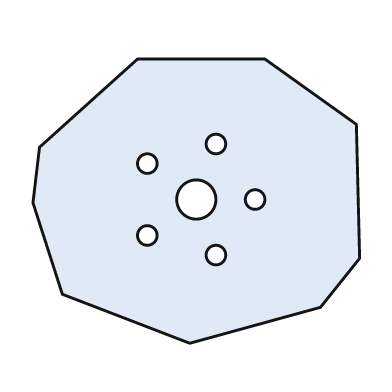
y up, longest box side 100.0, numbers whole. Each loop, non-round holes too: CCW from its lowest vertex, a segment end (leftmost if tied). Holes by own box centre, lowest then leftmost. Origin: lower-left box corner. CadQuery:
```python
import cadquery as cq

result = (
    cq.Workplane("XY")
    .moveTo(48.0, 0.0)
    .lineTo(88.0, 11.0)
    .lineTo(100.0, 26.0)
    .lineTo(99.0, 67.0)
    .lineTo(71.0, 87.0)
    .lineTo(32.0, 87.0)
    .lineTo(2.0, 60.0)
    .lineTo(0.0, 43.0)
    .lineTo(9.0, 15.0)
    .close()
    .moveTo(56.0, 27.0)
    .circle(3.0)
    .moveTo(35.0, 33.0)
    .circle(3.0)
    .moveTo(50.0, 44.0)
    .circle(6.0)
    .moveTo(68.0, 44.0)
    .circle(3.0)
    .moveTo(35.0, 55.0)
    .circle(3.0)
    .moveTo(56.0, 61.0)
    .circle(3.0)
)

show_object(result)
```